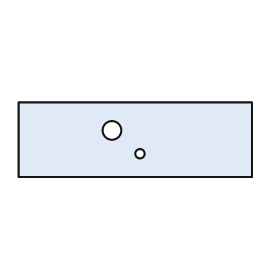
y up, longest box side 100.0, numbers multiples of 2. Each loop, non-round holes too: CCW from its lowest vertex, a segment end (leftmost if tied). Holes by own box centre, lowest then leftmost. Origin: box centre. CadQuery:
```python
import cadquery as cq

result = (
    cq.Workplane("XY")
    .moveTo(-50.0, -16.0)
    .lineTo(50.0, -16.0)
    .lineTo(50.0, 16.0)
    .lineTo(-50.0, 16.0)
    .close()
    .moveTo(2.0, -6.0)
    .circle(2.0)
    .moveTo(-10.0, 4.0)
    .circle(4.0)
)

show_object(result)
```